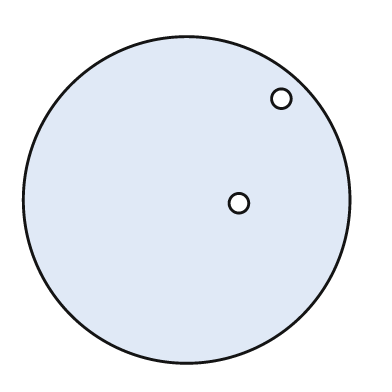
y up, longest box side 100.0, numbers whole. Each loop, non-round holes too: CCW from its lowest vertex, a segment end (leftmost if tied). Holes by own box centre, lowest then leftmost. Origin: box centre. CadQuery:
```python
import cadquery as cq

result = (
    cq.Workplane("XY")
    .moveTo(0.0, 0.0)
    .circle(50.0)
    .moveTo(16.0, -1.0)
    .circle(3.0)
    .moveTo(29.0, 31.0)
    .circle(3.0)
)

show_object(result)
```